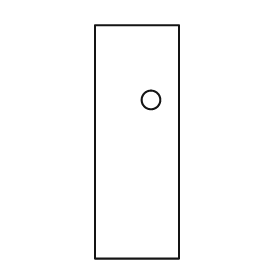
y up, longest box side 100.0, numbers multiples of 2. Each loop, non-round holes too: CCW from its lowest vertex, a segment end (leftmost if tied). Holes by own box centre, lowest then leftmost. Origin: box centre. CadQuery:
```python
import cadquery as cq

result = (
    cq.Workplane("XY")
    .moveTo(-18.0, -50.0)
    .lineTo(18.0, -50.0)
    .lineTo(18.0, 50.0)
    .lineTo(-18.0, 50.0)
    .close()
    .moveTo(6.0, 18.0)
    .circle(4.0)
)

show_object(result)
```